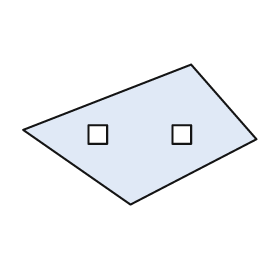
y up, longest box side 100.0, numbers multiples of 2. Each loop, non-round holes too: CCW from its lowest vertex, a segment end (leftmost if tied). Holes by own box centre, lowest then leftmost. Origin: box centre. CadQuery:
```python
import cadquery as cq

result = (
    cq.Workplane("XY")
    .moveTo(-4.0, -30.0)
    .lineTo(50.0, -2.0)
    .lineTo(22.0, 30.0)
    .lineTo(-50.0, 2.0)
    .close()
    .moveTo(-22.0, -4.0)
    .lineTo(-14.0, -4.0)
    .lineTo(-14.0, 4.0)
    .lineTo(-22.0, 4.0)
    .close()
    .moveTo(14.0, -4.0)
    .lineTo(22.0, -4.0)
    .lineTo(22.0, 4.0)
    .lineTo(14.0, 4.0)
    .close()
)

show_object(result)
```